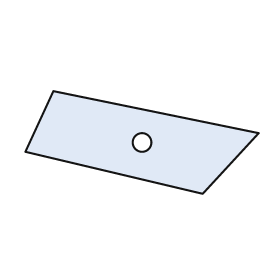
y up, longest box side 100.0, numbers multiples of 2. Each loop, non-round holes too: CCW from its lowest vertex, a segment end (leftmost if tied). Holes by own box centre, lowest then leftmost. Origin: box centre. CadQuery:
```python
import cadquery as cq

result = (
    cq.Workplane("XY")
    .moveTo(26.0, -22.0)
    .lineTo(50.0, 4.0)
    .lineTo(-38.0, 22.0)
    .lineTo(-50.0, -4.0)
    .close()
    .moveTo(0.0, 0.0)
    .circle(4.0)
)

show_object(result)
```